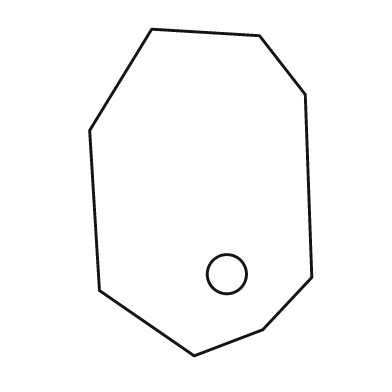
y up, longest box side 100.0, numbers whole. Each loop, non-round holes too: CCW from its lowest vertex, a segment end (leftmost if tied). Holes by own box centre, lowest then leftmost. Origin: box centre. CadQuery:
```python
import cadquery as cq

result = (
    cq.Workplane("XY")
    .moveTo(-2.0, -50.0)
    .lineTo(19.0, -42.0)
    .lineTo(34.0, -26.0)
    .lineTo(32.0, 30.0)
    .lineTo(18.0, 48.0)
    .lineTo(-15.0, 50.0)
    .lineTo(-34.0, 19.0)
    .lineTo(-31.0, -30.0)
    .close()
    .moveTo(8.0, -25.0)
    .circle(6.0)
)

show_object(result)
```